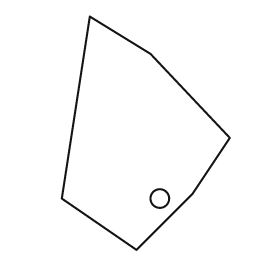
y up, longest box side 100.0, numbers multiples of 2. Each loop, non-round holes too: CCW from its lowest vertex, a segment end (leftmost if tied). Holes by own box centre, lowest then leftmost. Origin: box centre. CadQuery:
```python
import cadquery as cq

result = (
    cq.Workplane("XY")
    .moveTo(-4.0, -50.0)
    .lineTo(20.0, -26.0)
    .lineTo(36.0, -2.0)
    .lineTo(2.0, 34.0)
    .lineTo(-24.0, 50.0)
    .lineTo(-36.0, -28.0)
    .close()
    .moveTo(6.0, -28.0)
    .circle(4.0)
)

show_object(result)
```